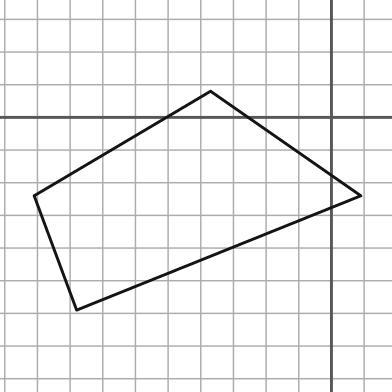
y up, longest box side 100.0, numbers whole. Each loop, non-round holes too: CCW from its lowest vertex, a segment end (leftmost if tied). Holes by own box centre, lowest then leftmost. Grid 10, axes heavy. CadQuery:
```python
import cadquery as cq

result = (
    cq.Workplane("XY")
    .moveTo(-78.0, -59.0)
    .lineTo(9.0, -24.0)
    .lineTo(-37.0, 8.0)
    .lineTo(-91.0, -24.0)
    .close()
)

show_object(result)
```